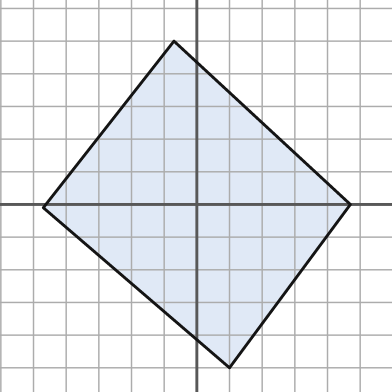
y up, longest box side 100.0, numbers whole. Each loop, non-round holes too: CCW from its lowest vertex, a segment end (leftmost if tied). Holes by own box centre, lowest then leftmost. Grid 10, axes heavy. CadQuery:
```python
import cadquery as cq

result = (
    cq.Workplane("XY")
    .moveTo(10.0, -50.0)
    .lineTo(47.0, 0.0)
    .lineTo(-7.0, 50.0)
    .lineTo(-47.0, -1.0)
    .close()
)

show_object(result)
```